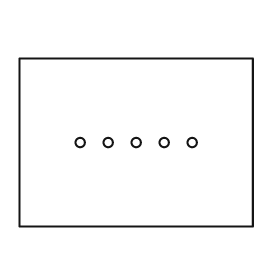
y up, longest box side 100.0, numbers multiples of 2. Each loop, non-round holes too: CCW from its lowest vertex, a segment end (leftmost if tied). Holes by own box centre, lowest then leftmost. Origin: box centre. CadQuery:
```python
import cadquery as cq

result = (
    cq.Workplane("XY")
    .moveTo(-50.0, -36.0)
    .lineTo(50.0, -36.0)
    .lineTo(50.0, 36.0)
    .lineTo(-50.0, 36.0)
    .close()
    .moveTo(-24.0, 0.0)
    .circle(2.0)
    .moveTo(-12.0, 0.0)
    .circle(2.0)
    .moveTo(0.0, 0.0)
    .circle(2.0)
    .moveTo(12.0, 0.0)
    .circle(2.0)
    .moveTo(24.0, 0.0)
    .circle(2.0)
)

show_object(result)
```